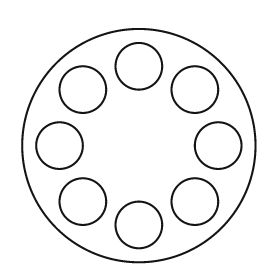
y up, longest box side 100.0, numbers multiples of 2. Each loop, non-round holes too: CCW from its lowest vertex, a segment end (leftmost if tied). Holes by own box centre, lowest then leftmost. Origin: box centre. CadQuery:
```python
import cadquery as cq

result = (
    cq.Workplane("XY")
    .moveTo(0.0, 0.0)
    .circle(50.0)
    .moveTo(0.0, -34.0)
    .circle(10.0)
    .moveTo(-24.0, -24.0)
    .circle(10.0)
    .moveTo(24.0, -24.0)
    .circle(10.0)
    .moveTo(-34.0, 0.0)
    .circle(10.0)
    .moveTo(34.0, 0.0)
    .circle(10.0)
    .moveTo(-24.0, 24.0)
    .circle(10.0)
    .moveTo(24.0, 24.0)
    .circle(10.0)
    .moveTo(0.0, 34.0)
    .circle(10.0)
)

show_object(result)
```